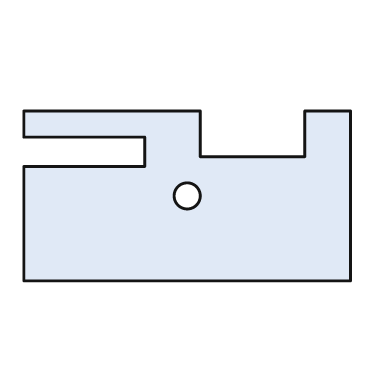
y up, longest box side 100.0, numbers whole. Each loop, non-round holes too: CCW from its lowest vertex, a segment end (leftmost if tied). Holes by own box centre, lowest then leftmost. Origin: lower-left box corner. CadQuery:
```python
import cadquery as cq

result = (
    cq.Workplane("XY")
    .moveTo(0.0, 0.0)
    .lineTo(100.0, 0.0)
    .lineTo(100.0, 52.0)
    .lineTo(86.0, 52.0)
    .lineTo(86.0, 38.0)
    .lineTo(54.0, 38.0)
    .lineTo(54.0, 52.0)
    .lineTo(0.0, 52.0)
    .lineTo(0.0, 44.0)
    .lineTo(37.0, 44.0)
    .lineTo(37.0, 35.0)
    .lineTo(0.0, 35.0)
    .close()
    .moveTo(50.0, 26.0)
    .circle(4.0)
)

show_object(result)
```